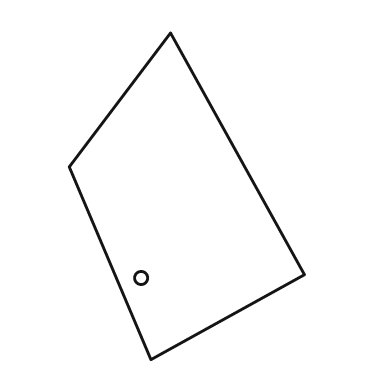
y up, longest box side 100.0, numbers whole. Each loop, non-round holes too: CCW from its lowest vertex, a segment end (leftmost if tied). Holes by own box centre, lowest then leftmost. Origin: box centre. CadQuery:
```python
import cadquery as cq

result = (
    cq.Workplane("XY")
    .moveTo(-11.0, -50.0)
    .lineTo(36.0, -24.0)
    .lineTo(-5.0, 50.0)
    .lineTo(-36.0, 9.0)
    .close()
    .moveTo(-14.0, -25.0)
    .circle(2.0)
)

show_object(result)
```